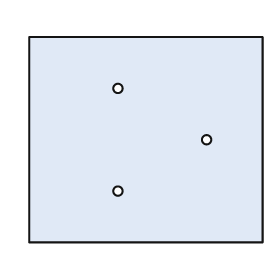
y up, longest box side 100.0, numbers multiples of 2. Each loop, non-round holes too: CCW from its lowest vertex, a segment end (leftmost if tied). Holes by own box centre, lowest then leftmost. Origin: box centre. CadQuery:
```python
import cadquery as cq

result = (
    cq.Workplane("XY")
    .moveTo(-50.0, -44.0)
    .lineTo(50.0, -44.0)
    .lineTo(50.0, 44.0)
    .lineTo(-50.0, 44.0)
    .close()
    .moveTo(-12.0, -22.0)
    .circle(2.0)
    .moveTo(26.0, 0.0)
    .circle(2.0)
    .moveTo(-12.0, 22.0)
    .circle(2.0)
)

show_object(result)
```